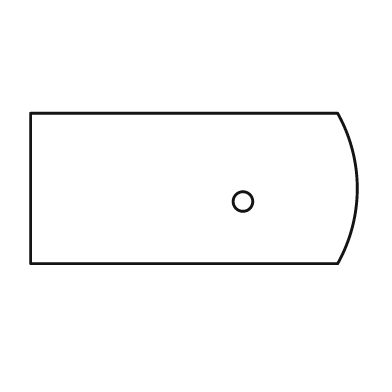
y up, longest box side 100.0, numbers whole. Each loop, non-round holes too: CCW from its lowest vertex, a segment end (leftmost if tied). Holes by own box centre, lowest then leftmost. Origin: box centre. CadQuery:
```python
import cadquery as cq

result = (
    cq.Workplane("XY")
    .moveTo(-50.0, -23.0)
    .lineTo(44.0, -23.0)
    .threePointArc((50.0, 0.0), (44.0, 23.0))
    .lineTo(-50.0, 23.0)
    .close()
    .moveTo(15.0, -4.0)
    .circle(3.0)
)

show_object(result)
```